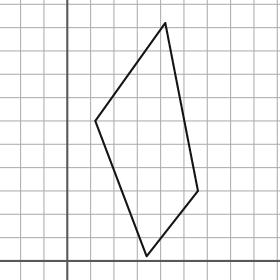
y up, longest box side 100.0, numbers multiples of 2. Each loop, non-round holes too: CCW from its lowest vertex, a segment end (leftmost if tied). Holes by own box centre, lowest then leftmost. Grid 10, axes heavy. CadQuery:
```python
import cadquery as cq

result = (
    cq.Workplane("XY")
    .moveTo(34.0, 2.0)
    .lineTo(56.0, 30.0)
    .lineTo(42.0, 102.0)
    .lineTo(12.0, 60.0)
    .close()
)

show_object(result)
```